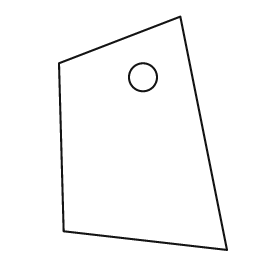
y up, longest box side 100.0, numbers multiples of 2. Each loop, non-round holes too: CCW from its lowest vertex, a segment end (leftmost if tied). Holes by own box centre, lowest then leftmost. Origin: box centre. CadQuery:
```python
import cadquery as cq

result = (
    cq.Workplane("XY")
    .moveTo(36.0, -50.0)
    .lineTo(16.0, 50.0)
    .lineTo(-36.0, 30.0)
    .lineTo(-34.0, -42.0)
    .close()
    .moveTo(0.0, 24.0)
    .circle(6.0)
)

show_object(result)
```